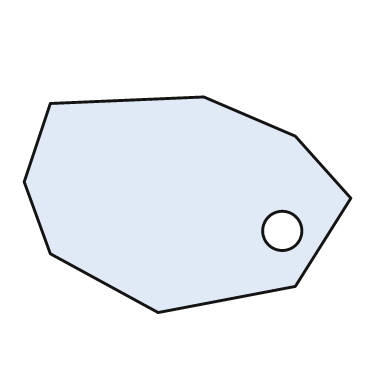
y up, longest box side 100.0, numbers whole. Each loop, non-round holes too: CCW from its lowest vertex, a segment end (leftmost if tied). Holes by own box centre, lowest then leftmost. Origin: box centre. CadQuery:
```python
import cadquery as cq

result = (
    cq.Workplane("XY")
    .moveTo(-9.0, -33.0)
    .lineTo(33.0, -25.0)
    .lineTo(50.0, 2.0)
    .lineTo(33.0, 21.0)
    .lineTo(5.0, 33.0)
    .lineTo(-42.0, 31.0)
    .lineTo(-50.0, 7.0)
    .lineTo(-42.0, -15.0)
    .close()
    .moveTo(29.0, -8.0)
    .circle(6.0)
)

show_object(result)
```